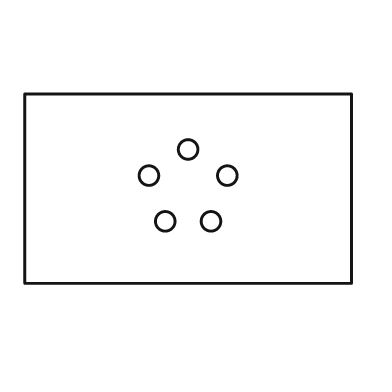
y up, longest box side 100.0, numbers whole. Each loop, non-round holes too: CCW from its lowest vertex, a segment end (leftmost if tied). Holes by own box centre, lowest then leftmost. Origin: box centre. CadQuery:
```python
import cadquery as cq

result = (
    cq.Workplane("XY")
    .moveTo(-50.0, -29.0)
    .lineTo(50.0, -29.0)
    .lineTo(50.0, 29.0)
    .lineTo(-50.0, 29.0)
    .close()
    .moveTo(-7.0, -10.0)
    .circle(3.0)
    .moveTo(7.0, -10.0)
    .circle(3.0)
    .moveTo(-12.0, 4.0)
    .circle(3.0)
    .moveTo(12.0, 4.0)
    .circle(3.0)
    .moveTo(0.0, 12.0)
    .circle(3.0)
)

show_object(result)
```